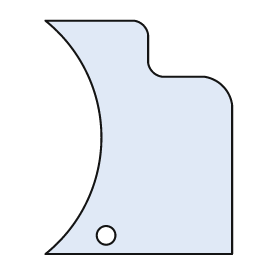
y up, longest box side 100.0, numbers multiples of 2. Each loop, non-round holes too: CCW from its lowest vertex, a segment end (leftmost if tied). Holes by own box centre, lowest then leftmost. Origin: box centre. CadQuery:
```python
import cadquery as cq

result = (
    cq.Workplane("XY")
    .moveTo(-40.0, -50.0)
    .lineTo(40.0, -50.0)
    .lineTo(40.0, 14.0)
    .threePointArc((36.0, 22.0), (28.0, 26.0))
    .lineTo(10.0, 26.0)
    .threePointArc((6.0, 28.0), (4.0, 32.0))
    .lineTo(4.0, 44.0)
    .threePointArc((2.0, 48.0), (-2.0, 50.0))
    .lineTo(-40.0, 50.0)
    .threePointArc((-16.0, 0.0), (-40.0, -50.0))
    .close()
    .moveTo(-14.0, -42.0)
    .circle(4.0)
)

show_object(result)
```